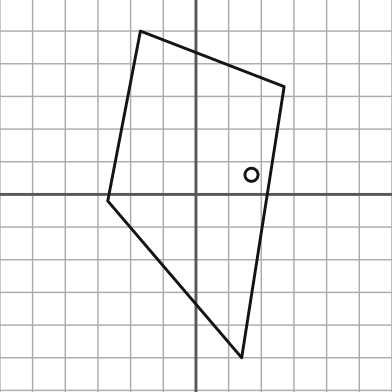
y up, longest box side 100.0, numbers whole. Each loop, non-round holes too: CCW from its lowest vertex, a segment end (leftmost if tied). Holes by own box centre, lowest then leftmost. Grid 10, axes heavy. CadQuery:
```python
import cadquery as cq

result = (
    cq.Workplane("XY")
    .moveTo(14.0, -50.0)
    .lineTo(27.0, 33.0)
    .lineTo(-17.0, 50.0)
    .lineTo(-27.0, -2.0)
    .close()
    .moveTo(17.0, 6.0)
    .circle(2.0)
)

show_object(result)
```